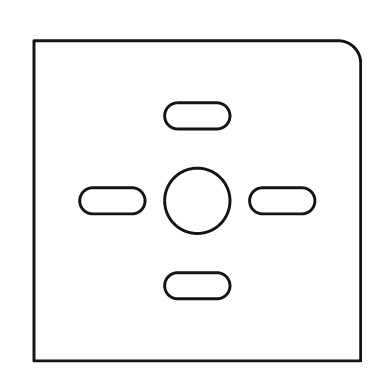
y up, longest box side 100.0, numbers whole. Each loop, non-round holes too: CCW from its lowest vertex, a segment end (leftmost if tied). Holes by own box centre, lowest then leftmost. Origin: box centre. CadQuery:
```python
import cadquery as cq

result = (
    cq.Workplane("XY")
    .moveTo(-50.0, -49.0)
    .lineTo(50.0, -49.0)
    .lineTo(50.0, 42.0)
    .threePointArc((48.0, 47.0), (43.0, 49.0))
    .lineTo(-50.0, 49.0)
    .close()
    .moveTo(-6.0, -30.0)
    .lineTo(6.0, -30.0)
    .threePointArc((10.0, -26.0), (6.0, -22.0))
    .lineTo(-6.0, -22.0)
    .threePointArc((-10.0, -26.0), (-6.0, -30.0))
    .close()
    .moveTo(-32.0, -4.0)
    .lineTo(-20.0, -4.0)
    .threePointArc((-16.0, 0.0), (-20.0, 4.0))
    .lineTo(-32.0, 4.0)
    .threePointArc((-36.0, 0.0), (-32.0, -4.0))
    .close()
    .moveTo(0.0, 0.0)
    .circle(10.0)
    .moveTo(20.0, -4.0)
    .lineTo(32.0, -4.0)
    .threePointArc((36.0, 0.0), (32.0, 4.0))
    .lineTo(20.0, 4.0)
    .threePointArc((16.0, 0.0), (20.0, -4.0))
    .close()
    .moveTo(-6.0, 22.0)
    .lineTo(6.0, 22.0)
    .threePointArc((10.0, 26.0), (6.0, 30.0))
    .lineTo(-6.0, 30.0)
    .threePointArc((-10.0, 26.0), (-6.0, 22.0))
    .close()
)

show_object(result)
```